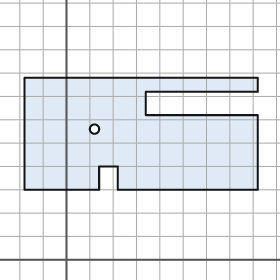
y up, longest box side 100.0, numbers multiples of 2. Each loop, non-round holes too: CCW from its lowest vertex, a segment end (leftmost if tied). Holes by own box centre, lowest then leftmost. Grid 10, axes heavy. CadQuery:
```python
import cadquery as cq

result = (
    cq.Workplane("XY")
    .moveTo(-18.0, 30.0)
    .lineTo(14.0, 30.0)
    .lineTo(14.0, 40.0)
    .lineTo(22.0, 40.0)
    .lineTo(22.0, 30.0)
    .lineTo(82.0, 30.0)
    .lineTo(82.0, 62.0)
    .lineTo(34.0, 62.0)
    .lineTo(34.0, 72.0)
    .lineTo(82.0, 72.0)
    .lineTo(82.0, 78.0)
    .lineTo(-18.0, 78.0)
    .close()
    .moveTo(12.0, 56.0)
    .circle(2.0)
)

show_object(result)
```